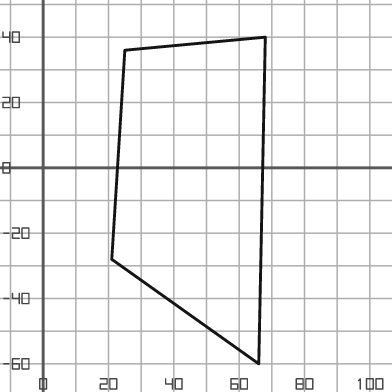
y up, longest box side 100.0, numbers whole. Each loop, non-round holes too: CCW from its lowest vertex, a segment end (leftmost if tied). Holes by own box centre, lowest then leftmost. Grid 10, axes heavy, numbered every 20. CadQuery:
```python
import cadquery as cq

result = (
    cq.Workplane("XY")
    .moveTo(66.0, -60.0)
    .lineTo(68.0, 40.0)
    .lineTo(25.0, 36.0)
    .lineTo(21.0, -28.0)
    .close()
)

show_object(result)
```